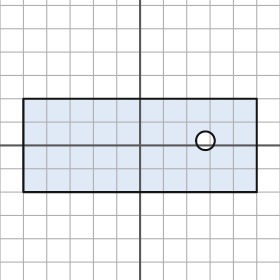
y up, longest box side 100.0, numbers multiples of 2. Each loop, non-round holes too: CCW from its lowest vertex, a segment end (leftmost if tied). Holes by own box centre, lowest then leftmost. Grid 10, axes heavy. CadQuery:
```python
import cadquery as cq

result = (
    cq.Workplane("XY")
    .moveTo(-50.0, -20.0)
    .lineTo(50.0, -20.0)
    .lineTo(50.0, 20.0)
    .lineTo(-50.0, 20.0)
    .close()
    .moveTo(28.0, 2.0)
    .circle(4.0)
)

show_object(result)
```